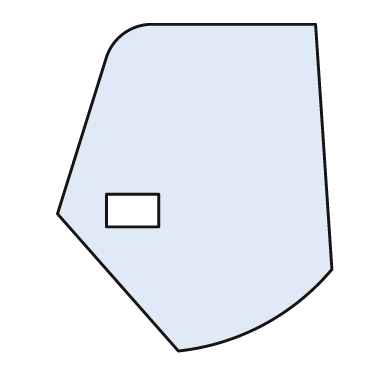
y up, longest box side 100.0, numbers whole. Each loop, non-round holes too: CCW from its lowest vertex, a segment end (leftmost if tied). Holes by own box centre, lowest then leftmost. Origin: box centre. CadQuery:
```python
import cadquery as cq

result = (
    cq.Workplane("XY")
    .moveTo(-5.0, -50.0)
    .threePointArc((21.0, -42.0), (42.0, -25.0))
    .lineTo(37.0, 50.0)
    .lineTo(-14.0, 50.0)
    .threePointArc((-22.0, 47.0), (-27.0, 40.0))
    .lineTo(-42.0, -8.0)
    .close()
    .moveTo(-27.0, -12.0)
    .lineTo(-11.0, -12.0)
    .lineTo(-11.0, -2.0)
    .lineTo(-27.0, -2.0)
    .close()
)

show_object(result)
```